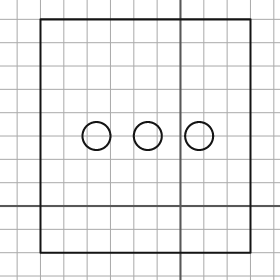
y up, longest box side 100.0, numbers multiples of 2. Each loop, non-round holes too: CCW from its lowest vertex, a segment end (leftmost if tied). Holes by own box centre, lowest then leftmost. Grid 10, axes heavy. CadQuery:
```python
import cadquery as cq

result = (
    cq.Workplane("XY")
    .moveTo(-60.0, -20.0)
    .lineTo(30.0, -20.0)
    .lineTo(30.0, 80.0)
    .lineTo(-60.0, 80.0)
    .close()
    .moveTo(-36.0, 30.0)
    .circle(6.0)
    .moveTo(-14.0, 30.0)
    .circle(6.0)
    .moveTo(8.0, 30.0)
    .circle(6.0)
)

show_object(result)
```